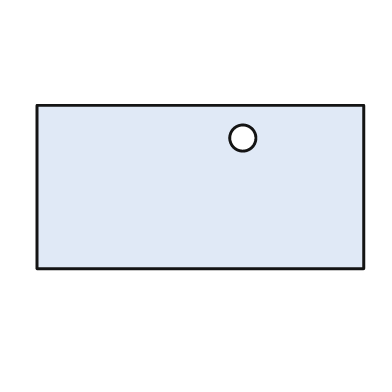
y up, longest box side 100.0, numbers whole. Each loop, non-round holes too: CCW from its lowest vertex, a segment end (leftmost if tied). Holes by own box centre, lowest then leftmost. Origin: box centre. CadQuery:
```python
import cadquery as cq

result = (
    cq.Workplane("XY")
    .moveTo(-50.0, -25.0)
    .lineTo(50.0, -25.0)
    .lineTo(50.0, 25.0)
    .lineTo(-50.0, 25.0)
    .close()
    .moveTo(13.0, 15.0)
    .circle(4.0)
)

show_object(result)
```